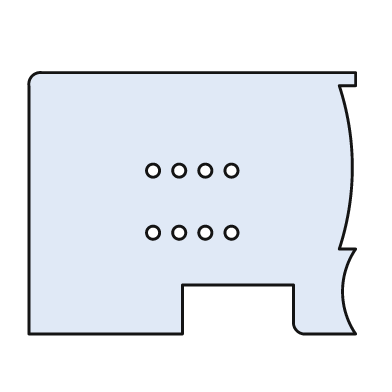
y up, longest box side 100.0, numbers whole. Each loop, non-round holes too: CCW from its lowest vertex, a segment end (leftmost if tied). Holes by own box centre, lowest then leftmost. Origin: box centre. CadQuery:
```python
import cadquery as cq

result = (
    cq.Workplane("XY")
    .moveTo(-50.0, -40.0)
    .lineTo(-3.0, -40.0)
    .lineTo(-3.0, -25.0)
    .lineTo(31.0, -25.0)
    .lineTo(31.0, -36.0)
    .threePointArc((32.0, -39.0), (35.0, -40.0))
    .lineTo(50.0, -40.0)
    .threePointArc((46.0, -27.0), (50.0, -14.0))
    .lineTo(45.0, -14.0)
    .threePointArc((49.0, 11.0), (45.0, 36.0))
    .lineTo(50.0, 36.0)
    .lineTo(50.0, 40.0)
    .lineTo(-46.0, 40.0)
    .threePointArc((-49.0, 39.0), (-50.0, 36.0))
    .close()
    .moveTo(-12.0, -9.0)
    .circle(2.0)
    .moveTo(-4.0, -9.0)
    .circle(2.0)
    .moveTo(4.0, -9.0)
    .circle(2.0)
    .moveTo(12.0, -9.0)
    .circle(2.0)
    .moveTo(-12.0, 10.0)
    .circle(2.0)
    .moveTo(-4.0, 10.0)
    .circle(2.0)
    .moveTo(4.0, 10.0)
    .circle(2.0)
    .moveTo(12.0, 10.0)
    .circle(2.0)
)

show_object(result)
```